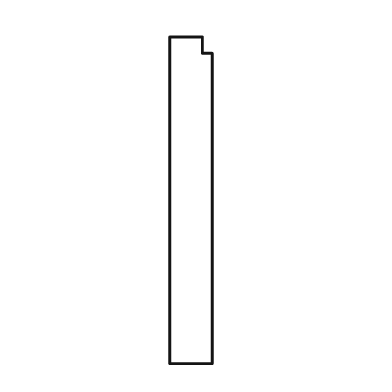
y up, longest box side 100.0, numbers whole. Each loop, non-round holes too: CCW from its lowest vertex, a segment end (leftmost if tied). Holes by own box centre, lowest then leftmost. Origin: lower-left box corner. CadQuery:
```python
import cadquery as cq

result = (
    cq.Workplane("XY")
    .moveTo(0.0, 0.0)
    .lineTo(13.0, 0.0)
    .lineTo(13.0, 95.0)
    .lineTo(10.0, 95.0)
    .lineTo(10.0, 100.0)
    .lineTo(0.0, 100.0)
    .close()
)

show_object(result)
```